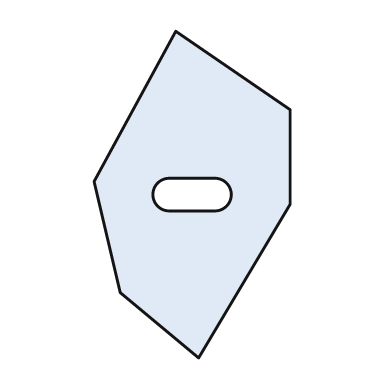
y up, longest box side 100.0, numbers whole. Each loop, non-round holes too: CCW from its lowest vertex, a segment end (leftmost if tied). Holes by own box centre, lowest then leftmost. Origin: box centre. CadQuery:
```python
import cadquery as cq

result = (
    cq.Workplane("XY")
    .moveTo(2.0, -50.0)
    .lineTo(30.0, -3.0)
    .lineTo(30.0, 26.0)
    .lineTo(-5.0, 50.0)
    .lineTo(-30.0, 4.0)
    .lineTo(-22.0, -30.0)
    .close()
    .moveTo(-7.0, -5.0)
    .lineTo(7.0, -5.0)
    .threePointArc((12.0, 0.0), (7.0, 5.0))
    .lineTo(-7.0, 5.0)
    .threePointArc((-12.0, 0.0), (-7.0, -5.0))
    .close()
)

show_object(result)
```